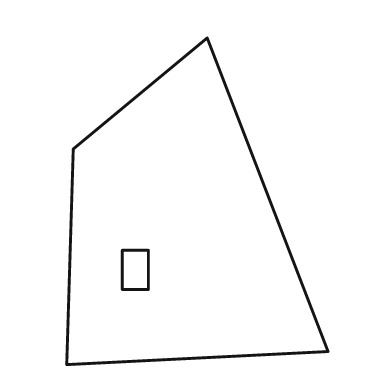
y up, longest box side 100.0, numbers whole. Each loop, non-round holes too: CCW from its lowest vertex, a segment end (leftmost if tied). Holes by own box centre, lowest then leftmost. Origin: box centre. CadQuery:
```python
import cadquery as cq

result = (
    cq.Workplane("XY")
    .moveTo(-40.0, -50.0)
    .lineTo(40.0, -46.0)
    .lineTo(3.0, 50.0)
    .lineTo(-38.0, 16.0)
    .close()
    .moveTo(-23.0, -27.0)
    .lineTo(-15.0, -27.0)
    .lineTo(-15.0, -15.0)
    .lineTo(-23.0, -15.0)
    .close()
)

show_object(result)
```